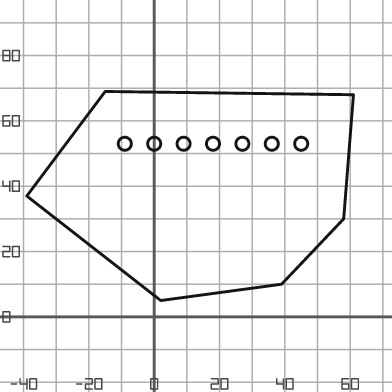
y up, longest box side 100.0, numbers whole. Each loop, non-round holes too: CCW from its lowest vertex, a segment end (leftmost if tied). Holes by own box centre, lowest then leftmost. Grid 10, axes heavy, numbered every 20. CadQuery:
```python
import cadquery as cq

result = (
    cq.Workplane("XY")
    .moveTo(2.0, 5.0)
    .lineTo(39.0, 10.0)
    .lineTo(58.0, 30.0)
    .lineTo(61.0, 68.0)
    .lineTo(-15.0, 69.0)
    .lineTo(-39.0, 37.0)
    .close()
    .moveTo(-9.0, 53.0)
    .circle(2.0)
    .moveTo(0.0, 53.0)
    .circle(2.0)
    .moveTo(9.0, 53.0)
    .circle(2.0)
    .moveTo(18.0, 53.0)
    .circle(2.0)
    .moveTo(27.0, 53.0)
    .circle(2.0)
    .moveTo(36.0, 53.0)
    .circle(2.0)
    .moveTo(45.0, 53.0)
    .circle(2.0)
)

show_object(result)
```